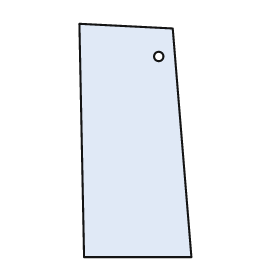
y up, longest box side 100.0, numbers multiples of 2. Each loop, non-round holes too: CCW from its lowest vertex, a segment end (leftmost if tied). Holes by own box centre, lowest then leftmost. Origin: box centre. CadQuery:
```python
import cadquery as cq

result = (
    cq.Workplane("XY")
    .moveTo(-22.0, -50.0)
    .lineTo(24.0, -50.0)
    .lineTo(16.0, 48.0)
    .lineTo(-24.0, 50.0)
    .close()
    .moveTo(10.0, 36.0)
    .circle(2.0)
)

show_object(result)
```